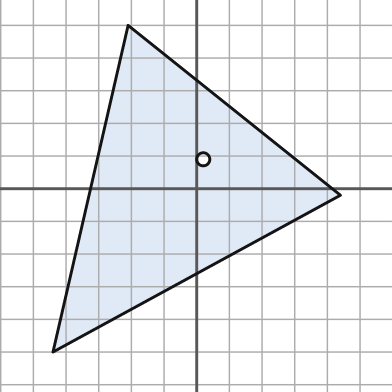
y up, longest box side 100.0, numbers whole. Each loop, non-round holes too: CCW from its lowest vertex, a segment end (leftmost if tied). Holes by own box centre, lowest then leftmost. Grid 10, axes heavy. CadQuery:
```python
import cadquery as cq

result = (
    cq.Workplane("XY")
    .moveTo(-44.0, -50.0)
    .lineTo(44.0, -2.0)
    .lineTo(-21.0, 50.0)
    .close()
    .moveTo(2.0, 9.0)
    .circle(2.0)
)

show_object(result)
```